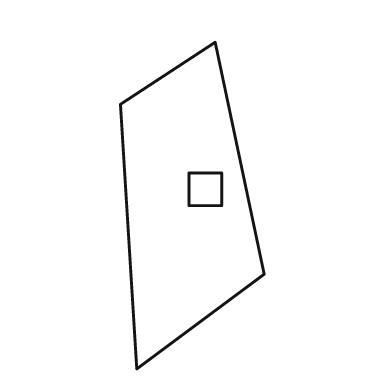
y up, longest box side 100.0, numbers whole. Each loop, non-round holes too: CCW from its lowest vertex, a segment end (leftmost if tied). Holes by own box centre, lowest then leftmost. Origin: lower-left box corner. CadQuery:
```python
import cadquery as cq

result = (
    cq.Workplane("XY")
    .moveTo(5.0, 0.0)
    .lineTo(44.0, 29.0)
    .lineTo(29.0, 100.0)
    .lineTo(0.0, 81.0)
    .close()
    .moveTo(21.0, 50.0)
    .lineTo(31.0, 50.0)
    .lineTo(31.0, 60.0)
    .lineTo(21.0, 60.0)
    .close()
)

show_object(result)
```